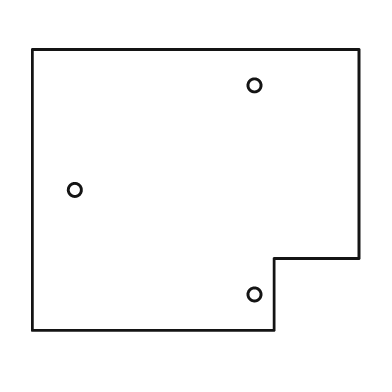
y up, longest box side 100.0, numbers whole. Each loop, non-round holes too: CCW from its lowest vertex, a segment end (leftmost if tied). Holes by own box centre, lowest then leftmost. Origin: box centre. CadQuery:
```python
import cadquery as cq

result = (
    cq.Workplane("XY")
    .moveTo(-50.0, -43.0)
    .lineTo(24.0, -43.0)
    .lineTo(24.0, -21.0)
    .lineTo(50.0, -21.0)
    .lineTo(50.0, 43.0)
    .lineTo(-50.0, 43.0)
    .close()
    .moveTo(18.0, -32.0)
    .circle(2.0)
    .moveTo(-37.0, 0.0)
    .circle(2.0)
    .moveTo(18.0, 32.0)
    .circle(2.0)
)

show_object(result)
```